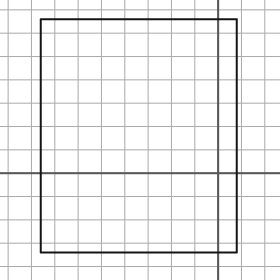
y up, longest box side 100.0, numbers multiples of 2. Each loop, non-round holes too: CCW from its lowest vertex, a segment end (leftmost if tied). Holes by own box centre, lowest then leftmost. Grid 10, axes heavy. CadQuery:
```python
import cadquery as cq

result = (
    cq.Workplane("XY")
    .moveTo(-76.0, -34.0)
    .lineTo(8.0, -34.0)
    .lineTo(8.0, 66.0)
    .lineTo(-76.0, 66.0)
    .close()
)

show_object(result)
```